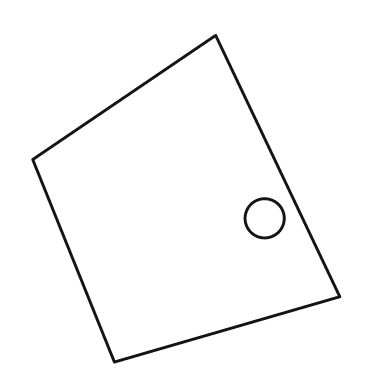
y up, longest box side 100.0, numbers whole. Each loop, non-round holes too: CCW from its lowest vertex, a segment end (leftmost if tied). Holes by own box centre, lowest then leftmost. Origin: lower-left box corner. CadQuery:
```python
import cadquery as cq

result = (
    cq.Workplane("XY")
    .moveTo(25.0, 0.0)
    .lineTo(94.0, 20.0)
    .lineTo(56.0, 100.0)
    .lineTo(0.0, 62.0)
    .close()
    .moveTo(71.0, 44.0)
    .circle(6.0)
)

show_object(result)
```